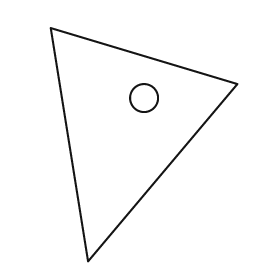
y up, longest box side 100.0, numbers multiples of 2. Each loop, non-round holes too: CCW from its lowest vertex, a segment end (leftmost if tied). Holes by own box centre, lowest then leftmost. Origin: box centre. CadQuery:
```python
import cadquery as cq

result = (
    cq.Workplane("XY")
    .moveTo(-24.0, -50.0)
    .lineTo(40.0, 26.0)
    .lineTo(-40.0, 50.0)
    .close()
    .moveTo(0.0, 20.0)
    .circle(6.0)
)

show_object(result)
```